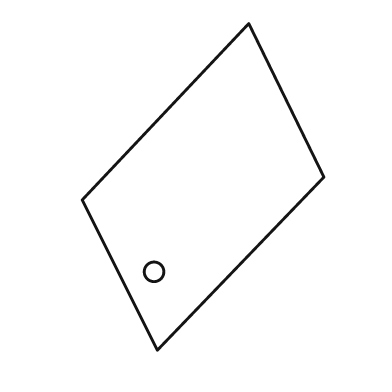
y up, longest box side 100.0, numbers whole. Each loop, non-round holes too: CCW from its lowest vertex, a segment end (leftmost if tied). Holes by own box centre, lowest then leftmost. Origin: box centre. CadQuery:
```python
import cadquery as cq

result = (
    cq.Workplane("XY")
    .moveTo(-14.0, -50.0)
    .lineTo(37.0, 3.0)
    .lineTo(14.0, 50.0)
    .lineTo(-37.0, -4.0)
    .close()
    .moveTo(-15.0, -26.0)
    .circle(3.0)
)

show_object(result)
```